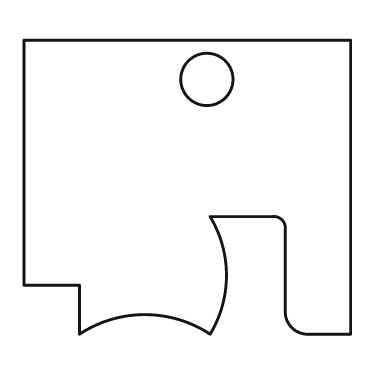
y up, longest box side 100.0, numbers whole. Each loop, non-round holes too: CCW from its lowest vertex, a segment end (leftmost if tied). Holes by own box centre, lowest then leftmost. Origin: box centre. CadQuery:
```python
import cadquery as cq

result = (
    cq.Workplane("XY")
    .moveTo(-33.0, -45.0)
    .threePointArc((-13.0, -39.0), (7.0, -45.0))
    .threePointArc((12.0, -27.0), (7.0, -9.0))
    .lineTo(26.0, -9.0)
    .threePointArc((29.0, -10.0), (30.0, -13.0))
    .lineTo(30.0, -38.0)
    .threePointArc((32.0, -43.0), (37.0, -45.0))
    .lineTo(50.0, -45.0)
    .lineTo(50.0, 45.0)
    .lineTo(-50.0, 45.0)
    .lineTo(-50.0, -30.0)
    .lineTo(-33.0, -30.0)
    .close()
    .moveTo(6.0, 33.0)
    .circle(8.0)
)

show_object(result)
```